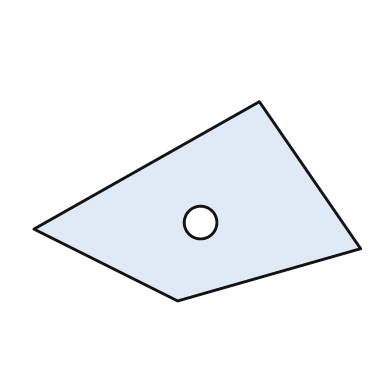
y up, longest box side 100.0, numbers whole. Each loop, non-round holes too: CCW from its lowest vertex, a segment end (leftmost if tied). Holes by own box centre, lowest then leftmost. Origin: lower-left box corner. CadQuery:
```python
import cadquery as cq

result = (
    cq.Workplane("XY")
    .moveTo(44.0, 0.0)
    .lineTo(100.0, 16.0)
    .lineTo(69.0, 61.0)
    .lineTo(0.0, 22.0)
    .close()
    .moveTo(51.0, 24.0)
    .circle(5.0)
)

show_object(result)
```